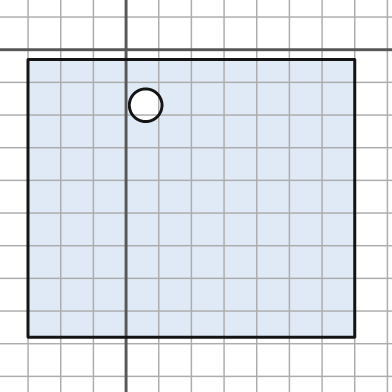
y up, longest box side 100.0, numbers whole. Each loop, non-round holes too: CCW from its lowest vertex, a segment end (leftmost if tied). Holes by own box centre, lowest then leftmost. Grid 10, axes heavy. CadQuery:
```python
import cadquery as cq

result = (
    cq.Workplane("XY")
    .moveTo(-30.0, -88.0)
    .lineTo(70.0, -88.0)
    .lineTo(70.0, -3.0)
    .lineTo(-30.0, -3.0)
    .close()
    .moveTo(6.0, -17.0)
    .circle(5.0)
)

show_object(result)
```